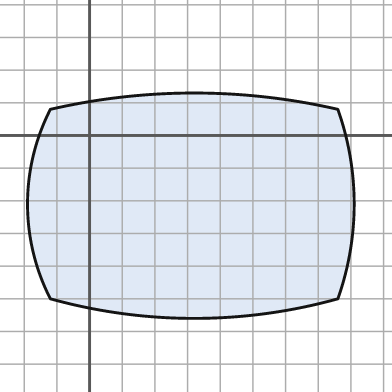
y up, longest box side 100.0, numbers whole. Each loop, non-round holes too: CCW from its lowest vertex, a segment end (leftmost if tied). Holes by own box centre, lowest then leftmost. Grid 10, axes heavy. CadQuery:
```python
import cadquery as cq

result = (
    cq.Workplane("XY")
    .moveTo(-12.0, -50.0)
    .threePointArc((32.0, -56.0), (76.0, -50.0))
    .threePointArc((81.0, -21.0), (76.0, 8.0))
    .threePointArc((32.0, 13.0), (-12.0, 8.0))
    .threePointArc((-19.0, -21.0), (-12.0, -50.0))
    .close()
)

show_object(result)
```